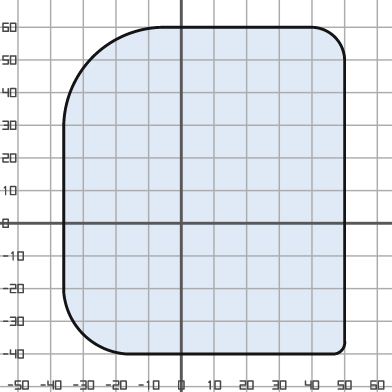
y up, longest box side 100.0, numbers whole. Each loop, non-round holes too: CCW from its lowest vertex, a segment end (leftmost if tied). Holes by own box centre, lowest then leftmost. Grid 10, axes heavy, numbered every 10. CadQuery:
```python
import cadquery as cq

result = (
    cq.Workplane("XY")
    .moveTo(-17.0, -40.0)
    .lineTo(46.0, -40.0)
    .threePointArc((49.0, -39.0), (50.0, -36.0))
    .lineTo(50.0, 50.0)
    .threePointArc((47.0, 57.0), (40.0, 60.0))
    .lineTo(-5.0, 60.0)
    .threePointArc((-27.0, 51.0), (-36.0, 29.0))
    .lineTo(-36.0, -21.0)
    .threePointArc((-30.0, -34.0), (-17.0, -40.0))
    .close()
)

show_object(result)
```